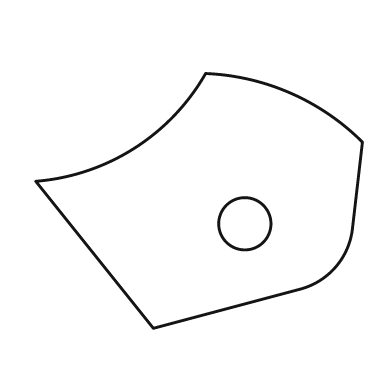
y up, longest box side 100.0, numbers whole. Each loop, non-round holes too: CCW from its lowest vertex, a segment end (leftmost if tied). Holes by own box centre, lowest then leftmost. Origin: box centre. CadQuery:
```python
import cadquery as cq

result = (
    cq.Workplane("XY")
    .moveTo(-14.0, -39.0)
    .lineTo(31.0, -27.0)
    .threePointArc((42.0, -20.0), (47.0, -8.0))
    .lineTo(50.0, 18.0)
    .threePointArc((28.0, 33.0), (2.0, 39.0))
    .threePointArc((-20.0, 16.0), (-50.0, 6.0))
    .close()
    .moveTo(14.0, -7.0)
    .circle(8.0)
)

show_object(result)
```